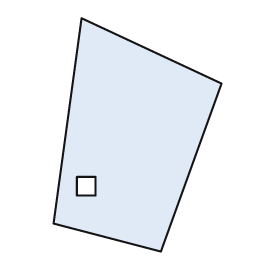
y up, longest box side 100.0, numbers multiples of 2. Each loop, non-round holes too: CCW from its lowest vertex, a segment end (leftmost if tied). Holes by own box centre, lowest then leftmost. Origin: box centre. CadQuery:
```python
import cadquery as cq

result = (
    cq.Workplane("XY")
    .moveTo(10.0, -50.0)
    .lineTo(36.0, 22.0)
    .lineTo(-24.0, 50.0)
    .lineTo(-36.0, -38.0)
    .close()
    .moveTo(-26.0, -26.0)
    .lineTo(-18.0, -26.0)
    .lineTo(-18.0, -18.0)
    .lineTo(-26.0, -18.0)
    .close()
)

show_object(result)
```